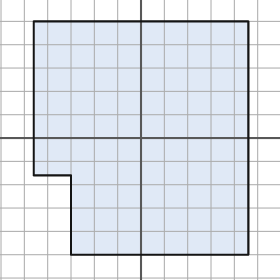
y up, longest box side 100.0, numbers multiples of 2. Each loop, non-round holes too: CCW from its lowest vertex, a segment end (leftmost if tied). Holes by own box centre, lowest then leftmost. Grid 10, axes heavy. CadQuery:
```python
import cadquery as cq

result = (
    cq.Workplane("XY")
    .moveTo(-30.0, -50.0)
    .lineTo(46.0, -50.0)
    .lineTo(46.0, 50.0)
    .lineTo(-46.0, 50.0)
    .lineTo(-46.0, -16.0)
    .lineTo(-30.0, -16.0)
    .close()
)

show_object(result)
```